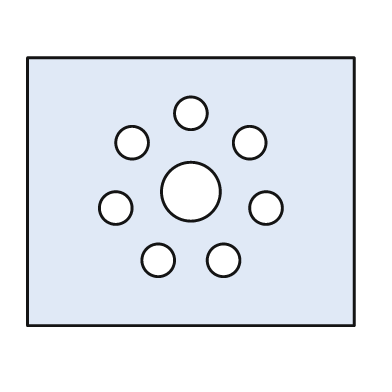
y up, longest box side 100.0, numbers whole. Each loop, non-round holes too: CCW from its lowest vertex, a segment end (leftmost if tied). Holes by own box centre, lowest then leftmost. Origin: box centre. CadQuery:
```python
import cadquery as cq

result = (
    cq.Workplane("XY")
    .moveTo(-50.0, -41.0)
    .lineTo(50.0, -41.0)
    .lineTo(50.0, 41.0)
    .lineTo(-50.0, 41.0)
    .close()
    .moveTo(-10.0, -21.0)
    .circle(5.0)
    .moveTo(10.0, -21.0)
    .circle(5.0)
    .moveTo(-23.0, -5.0)
    .circle(5.0)
    .moveTo(23.0, -5.0)
    .circle(5.0)
    .moveTo(0.0, 0.0)
    .circle(9.0)
    .moveTo(-18.0, 15.0)
    .circle(5.0)
    .moveTo(18.0, 15.0)
    .circle(5.0)
    .moveTo(0.0, 24.0)
    .circle(5.0)
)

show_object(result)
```